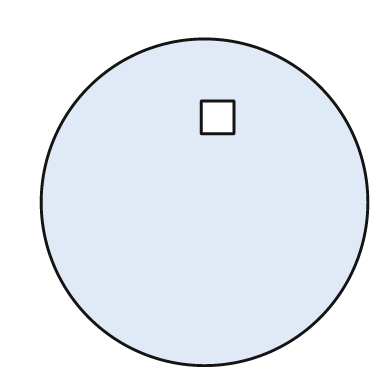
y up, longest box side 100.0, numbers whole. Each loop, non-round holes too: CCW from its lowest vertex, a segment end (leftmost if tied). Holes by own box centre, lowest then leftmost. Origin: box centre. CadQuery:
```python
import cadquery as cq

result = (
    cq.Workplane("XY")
    .moveTo(0.0, 0.0)
    .circle(50.0)
    .moveTo(-1.0, 21.0)
    .lineTo(9.0, 21.0)
    .lineTo(9.0, 31.0)
    .lineTo(-1.0, 31.0)
    .close()
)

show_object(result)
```